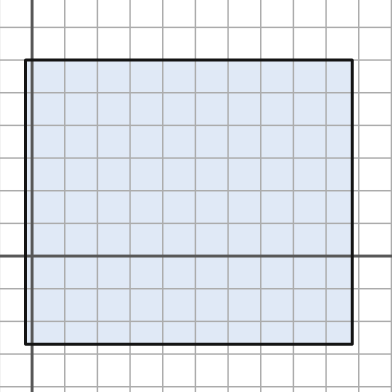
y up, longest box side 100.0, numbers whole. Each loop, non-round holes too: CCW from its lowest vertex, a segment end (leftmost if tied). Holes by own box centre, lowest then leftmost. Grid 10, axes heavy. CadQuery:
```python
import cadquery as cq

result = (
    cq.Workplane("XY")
    .moveTo(-2.0, -27.0)
    .lineTo(98.0, -27.0)
    .lineTo(98.0, 60.0)
    .lineTo(-2.0, 60.0)
    .close()
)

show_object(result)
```